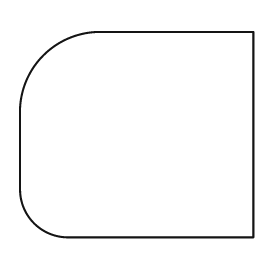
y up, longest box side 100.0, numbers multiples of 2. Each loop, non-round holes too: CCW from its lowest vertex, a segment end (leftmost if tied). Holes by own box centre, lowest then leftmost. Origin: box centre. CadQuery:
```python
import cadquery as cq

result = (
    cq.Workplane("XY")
    .moveTo(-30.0, -44.0)
    .lineTo(50.0, -44.0)
    .lineTo(50.0, 44.0)
    .lineTo(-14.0, 44.0)
    .threePointArc((-40.0, 34.0), (-50.0, 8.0))
    .lineTo(-50.0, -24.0)
    .threePointArc((-44.0, -38.0), (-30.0, -44.0))
    .close()
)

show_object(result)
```